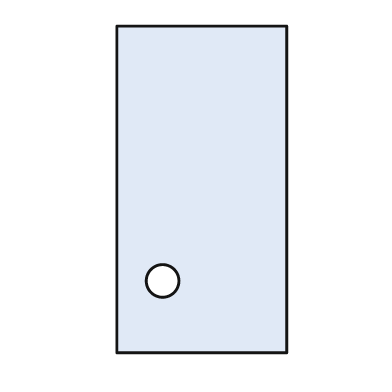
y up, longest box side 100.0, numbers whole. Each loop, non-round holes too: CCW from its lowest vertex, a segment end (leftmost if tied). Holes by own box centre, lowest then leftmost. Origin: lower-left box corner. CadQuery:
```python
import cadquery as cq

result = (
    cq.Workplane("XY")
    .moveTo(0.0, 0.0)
    .lineTo(52.0, 0.0)
    .lineTo(52.0, 100.0)
    .lineTo(0.0, 100.0)
    .close()
    .moveTo(14.0, 22.0)
    .circle(5.0)
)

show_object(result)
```